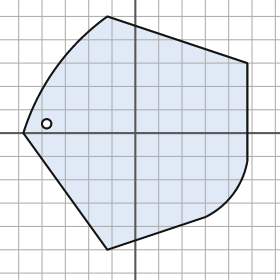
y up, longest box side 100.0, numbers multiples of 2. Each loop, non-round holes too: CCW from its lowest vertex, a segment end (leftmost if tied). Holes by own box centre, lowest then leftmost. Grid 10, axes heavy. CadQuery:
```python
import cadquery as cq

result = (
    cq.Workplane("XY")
    .moveTo(-12.0, -50.0)
    .lineTo(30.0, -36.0)
    .threePointArc((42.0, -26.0), (48.0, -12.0))
    .lineTo(48.0, 30.0)
    .lineTo(-12.0, 50.0)
    .threePointArc((-34.0, 28.0), (-48.0, 0.0))
    .close()
    .moveTo(-38.0, 4.0)
    .circle(2.0)
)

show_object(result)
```